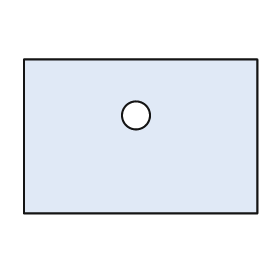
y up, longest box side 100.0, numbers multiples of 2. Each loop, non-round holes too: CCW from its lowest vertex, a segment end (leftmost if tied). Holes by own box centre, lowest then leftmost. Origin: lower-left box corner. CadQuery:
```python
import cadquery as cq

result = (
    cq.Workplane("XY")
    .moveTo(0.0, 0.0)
    .lineTo(100.0, 0.0)
    .lineTo(100.0, 66.0)
    .lineTo(0.0, 66.0)
    .close()
    .moveTo(48.0, 42.0)
    .circle(6.0)
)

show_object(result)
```